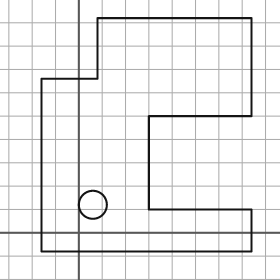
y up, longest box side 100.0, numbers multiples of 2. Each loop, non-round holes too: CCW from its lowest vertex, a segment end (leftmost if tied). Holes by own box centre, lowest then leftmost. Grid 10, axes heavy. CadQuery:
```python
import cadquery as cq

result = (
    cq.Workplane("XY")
    .moveTo(-16.0, -8.0)
    .lineTo(74.0, -8.0)
    .lineTo(74.0, 10.0)
    .lineTo(30.0, 10.0)
    .lineTo(30.0, 50.0)
    .lineTo(74.0, 50.0)
    .lineTo(74.0, 92.0)
    .lineTo(8.0, 92.0)
    .lineTo(8.0, 66.0)
    .lineTo(-16.0, 66.0)
    .close()
    .moveTo(6.0, 12.0)
    .circle(6.0)
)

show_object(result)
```